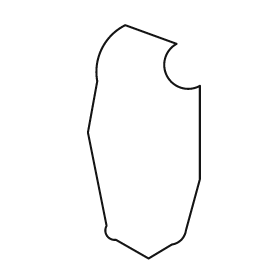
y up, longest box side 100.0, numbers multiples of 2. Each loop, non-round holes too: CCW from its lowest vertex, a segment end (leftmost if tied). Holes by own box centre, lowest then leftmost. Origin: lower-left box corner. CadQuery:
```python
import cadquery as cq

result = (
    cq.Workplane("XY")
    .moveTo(26.0, 0.0)
    .lineTo(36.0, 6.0)
    .threePointArc((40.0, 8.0), (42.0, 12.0))
    .lineTo(48.0, 34.0)
    .lineTo(48.0, 74.0)
    .threePointArc((34.0, 78.0), (38.0, 92.0))
    .lineTo(16.0, 100.0)
    .threePointArc((6.0, 90.0), (4.0, 76.0))
    .lineTo(0.0, 54.0)
    .lineTo(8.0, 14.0)
    .threePointArc((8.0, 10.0), (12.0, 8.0))
    .close()
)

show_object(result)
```